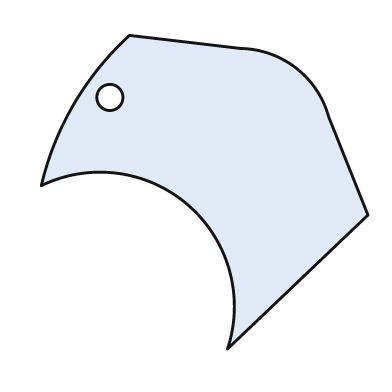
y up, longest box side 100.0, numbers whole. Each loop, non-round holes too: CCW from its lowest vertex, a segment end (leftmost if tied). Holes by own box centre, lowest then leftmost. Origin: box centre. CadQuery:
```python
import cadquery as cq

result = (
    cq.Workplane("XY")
    .moveTo(7.0, -48.0)
    .lineTo(50.0, -7.0)
    .lineTo(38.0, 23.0)
    .threePointArc((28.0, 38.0), (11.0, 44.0))
    .lineTo(-23.0, 48.0)
    .threePointArc((-40.0, 27.0), (-50.0, 2.0))
    .threePointArc((-5.0, -4.0), (7.0, -48.0))
    .close()
    .moveTo(-29.0, 29.0)
    .circle(4.0)
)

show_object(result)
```